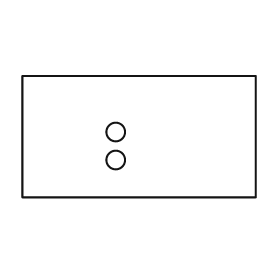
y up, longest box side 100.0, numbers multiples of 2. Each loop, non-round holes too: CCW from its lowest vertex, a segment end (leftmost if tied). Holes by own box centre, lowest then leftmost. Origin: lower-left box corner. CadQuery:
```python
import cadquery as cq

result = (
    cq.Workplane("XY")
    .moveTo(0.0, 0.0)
    .lineTo(100.0, 0.0)
    .lineTo(100.0, 52.0)
    .lineTo(0.0, 52.0)
    .close()
    .moveTo(40.0, 16.0)
    .circle(4.0)
    .moveTo(40.0, 28.0)
    .circle(4.0)
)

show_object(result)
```